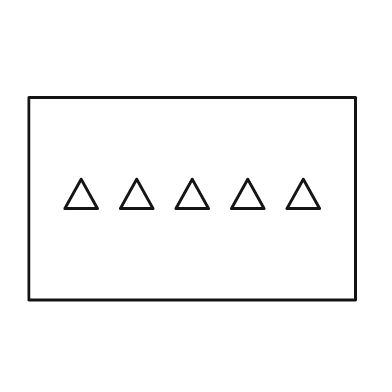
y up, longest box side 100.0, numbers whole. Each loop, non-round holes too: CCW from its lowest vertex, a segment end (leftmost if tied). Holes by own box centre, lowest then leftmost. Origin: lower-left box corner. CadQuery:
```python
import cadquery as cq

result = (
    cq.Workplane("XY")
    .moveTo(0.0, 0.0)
    .lineTo(100.0, 0.0)
    .lineTo(100.0, 62.0)
    .lineTo(0.0, 62.0)
    .close()
    .moveTo(11.0, 28.0)
    .lineTo(21.0, 28.0)
    .lineTo(16.0, 37.0)
    .close()
    .moveTo(28.0, 28.0)
    .lineTo(38.0, 28.0)
    .lineTo(33.0, 37.0)
    .close()
    .moveTo(45.0, 28.0)
    .lineTo(55.0, 28.0)
    .lineTo(50.0, 37.0)
    .close()
    .moveTo(62.0, 28.0)
    .lineTo(72.0, 28.0)
    .lineTo(67.0, 37.0)
    .close()
    .moveTo(79.0, 28.0)
    .lineTo(89.0, 28.0)
    .lineTo(84.0, 37.0)
    .close()
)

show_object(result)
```